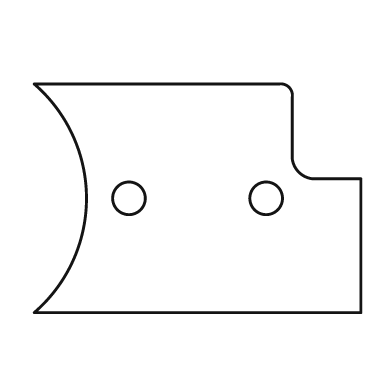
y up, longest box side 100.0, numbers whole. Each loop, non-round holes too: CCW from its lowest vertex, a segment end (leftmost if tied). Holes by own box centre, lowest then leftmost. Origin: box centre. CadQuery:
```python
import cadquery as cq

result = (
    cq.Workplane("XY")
    .moveTo(-50.0, -35.0)
    .lineTo(50.0, -35.0)
    .lineTo(50.0, 6.0)
    .lineTo(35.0, 6.0)
    .threePointArc((31.0, 8.0), (29.0, 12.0))
    .lineTo(29.0, 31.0)
    .threePointArc((28.0, 34.0), (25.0, 35.0))
    .lineTo(-50.0, 35.0)
    .threePointArc((-34.0, 0.0), (-50.0, -35.0))
    .close()
    .moveTo(-21.0, 0.0)
    .circle(5.0)
    .moveTo(21.0, 0.0)
    .circle(5.0)
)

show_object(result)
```